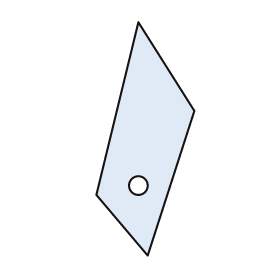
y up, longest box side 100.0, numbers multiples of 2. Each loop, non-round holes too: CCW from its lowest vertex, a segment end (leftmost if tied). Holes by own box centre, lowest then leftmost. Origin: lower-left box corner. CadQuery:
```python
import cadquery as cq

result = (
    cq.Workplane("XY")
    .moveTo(22.0, 0.0)
    .lineTo(42.0, 62.0)
    .lineTo(18.0, 100.0)
    .lineTo(0.0, 26.0)
    .close()
    .moveTo(18.0, 30.0)
    .circle(4.0)
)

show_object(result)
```